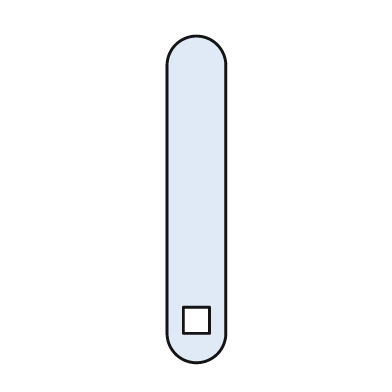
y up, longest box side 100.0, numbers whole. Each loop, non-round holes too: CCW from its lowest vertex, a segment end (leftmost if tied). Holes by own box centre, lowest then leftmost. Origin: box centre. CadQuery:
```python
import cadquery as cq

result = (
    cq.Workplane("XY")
    .moveTo(-9.0, -41.0)
    .threePointArc((0.0, -50.0), (9.0, -41.0))
    .lineTo(9.0, 41.0)
    .threePointArc((0.0, 50.0), (-9.0, 41.0))
    .close()
    .moveTo(-4.0, -41.0)
    .lineTo(4.0, -41.0)
    .lineTo(4.0, -33.0)
    .lineTo(-4.0, -33.0)
    .close()
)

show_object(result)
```